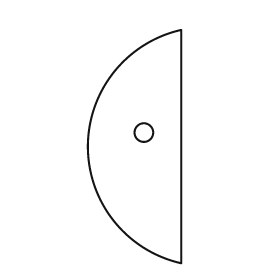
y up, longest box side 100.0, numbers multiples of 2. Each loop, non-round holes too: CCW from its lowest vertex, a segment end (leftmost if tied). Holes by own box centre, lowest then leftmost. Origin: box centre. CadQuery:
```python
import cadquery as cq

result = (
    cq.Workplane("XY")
    .moveTo(20.0, -50.0)
    .lineTo(20.0, 50.0)
    .threePointArc((-20.0, 0.0), (20.0, -50.0))
    .close()
    .moveTo(4.0, 6.0)
    .circle(4.0)
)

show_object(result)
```